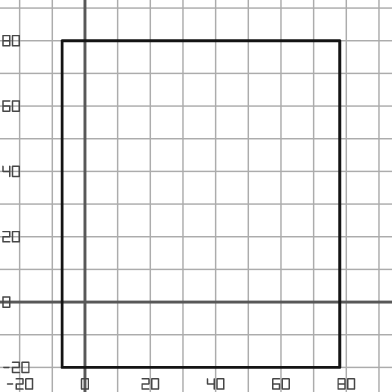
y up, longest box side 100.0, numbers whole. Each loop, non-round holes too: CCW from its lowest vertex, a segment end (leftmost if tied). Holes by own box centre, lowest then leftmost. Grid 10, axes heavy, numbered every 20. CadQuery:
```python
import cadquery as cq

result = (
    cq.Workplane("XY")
    .moveTo(-7.0, -20.0)
    .lineTo(78.0, -20.0)
    .lineTo(78.0, 80.0)
    .lineTo(-7.0, 80.0)
    .close()
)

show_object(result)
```